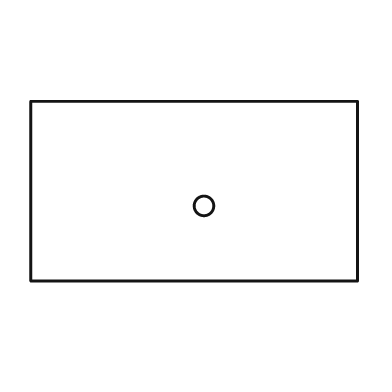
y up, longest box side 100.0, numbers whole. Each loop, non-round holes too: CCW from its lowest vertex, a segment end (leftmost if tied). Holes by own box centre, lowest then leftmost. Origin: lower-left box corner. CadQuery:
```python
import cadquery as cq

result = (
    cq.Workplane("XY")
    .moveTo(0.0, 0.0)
    .lineTo(100.0, 0.0)
    .lineTo(100.0, 55.0)
    .lineTo(0.0, 55.0)
    .close()
    .moveTo(53.0, 23.0)
    .circle(3.0)
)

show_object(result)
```